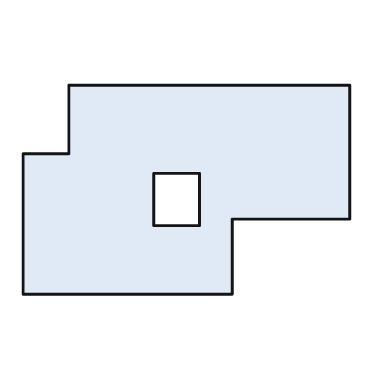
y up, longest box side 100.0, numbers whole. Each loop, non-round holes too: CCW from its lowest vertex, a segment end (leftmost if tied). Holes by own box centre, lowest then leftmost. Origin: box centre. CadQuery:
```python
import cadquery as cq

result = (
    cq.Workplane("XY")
    .moveTo(-50.0, -32.0)
    .lineTo(14.0, -32.0)
    .lineTo(14.0, -9.0)
    .lineTo(50.0, -9.0)
    .lineTo(50.0, 32.0)
    .lineTo(-36.0, 32.0)
    .lineTo(-36.0, 11.0)
    .lineTo(-50.0, 11.0)
    .close()
    .moveTo(-10.0, -11.0)
    .lineTo(4.0, -11.0)
    .lineTo(4.0, 5.0)
    .lineTo(-10.0, 5.0)
    .close()
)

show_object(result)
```